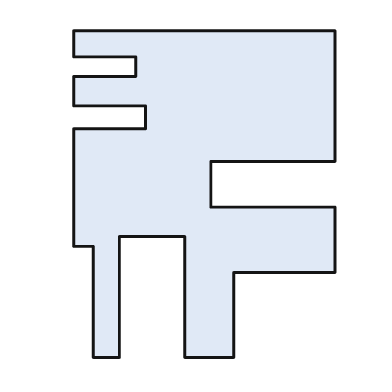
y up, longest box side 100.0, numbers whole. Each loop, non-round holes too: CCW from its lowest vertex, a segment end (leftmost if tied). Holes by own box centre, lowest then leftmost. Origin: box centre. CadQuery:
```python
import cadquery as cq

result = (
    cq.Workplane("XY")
    .moveTo(-34.0, -50.0)
    .lineTo(-26.0, -50.0)
    .lineTo(-26.0, -13.0)
    .lineTo(-6.0, -13.0)
    .lineTo(-6.0, -50.0)
    .lineTo(9.0, -50.0)
    .lineTo(9.0, -24.0)
    .lineTo(40.0, -24.0)
    .lineTo(40.0, -4.0)
    .lineTo(2.0, -4.0)
    .lineTo(2.0, 10.0)
    .lineTo(40.0, 10.0)
    .lineTo(40.0, 50.0)
    .lineTo(-40.0, 50.0)
    .lineTo(-40.0, 42.0)
    .lineTo(-21.0, 42.0)
    .lineTo(-21.0, 36.0)
    .lineTo(-40.0, 36.0)
    .lineTo(-40.0, 27.0)
    .lineTo(-18.0, 27.0)
    .lineTo(-18.0, 20.0)
    .lineTo(-40.0, 20.0)
    .lineTo(-40.0, -16.0)
    .lineTo(-34.0, -16.0)
    .close()
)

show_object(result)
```